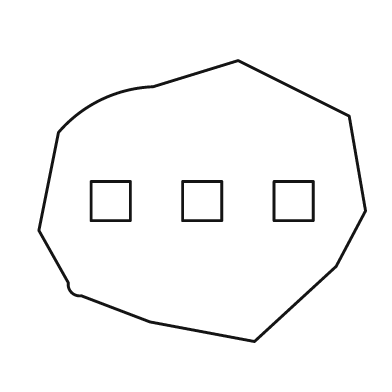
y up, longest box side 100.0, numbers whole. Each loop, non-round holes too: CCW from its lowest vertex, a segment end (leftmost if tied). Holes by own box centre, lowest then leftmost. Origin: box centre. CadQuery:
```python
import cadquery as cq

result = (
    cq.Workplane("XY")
    .moveTo(16.0, -43.0)
    .lineTo(41.0, -20.0)
    .lineTo(50.0, -3.0)
    .lineTo(45.0, 26.0)
    .lineTo(11.0, 43.0)
    .lineTo(-15.0, 35.0)
    .threePointArc((-31.0, 31.0), (-44.0, 21.0))
    .lineTo(-50.0, -9.0)
    .lineTo(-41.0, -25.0)
    .threePointArc((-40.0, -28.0), (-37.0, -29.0))
    .lineTo(-16.0, -37.0)
    .close()
    .moveTo(-34.0, -6.0)
    .lineTo(-22.0, -6.0)
    .lineTo(-22.0, 6.0)
    .lineTo(-34.0, 6.0)
    .close()
    .moveTo(-6.0, -6.0)
    .lineTo(6.0, -6.0)
    .lineTo(6.0, 6.0)
    .lineTo(-6.0, 6.0)
    .close()
    .moveTo(22.0, -6.0)
    .lineTo(34.0, -6.0)
    .lineTo(34.0, 6.0)
    .lineTo(22.0, 6.0)
    .close()
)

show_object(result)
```